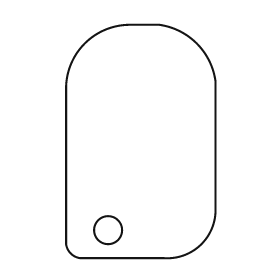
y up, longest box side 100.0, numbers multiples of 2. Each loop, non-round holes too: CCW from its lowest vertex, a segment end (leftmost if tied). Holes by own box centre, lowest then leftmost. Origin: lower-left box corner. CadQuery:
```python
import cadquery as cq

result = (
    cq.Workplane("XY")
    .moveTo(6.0, 0.0)
    .lineTo(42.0, 0.0)
    .threePointArc((58.0, 6.0), (64.0, 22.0))
    .lineTo(64.0, 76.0)
    .threePointArc((56.0, 92.0), (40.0, 100.0))
    .lineTo(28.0, 100.0)
    .threePointArc((8.0, 92.0), (0.0, 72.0))
    .lineTo(0.0, 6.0)
    .threePointArc((2.0, 2.0), (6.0, 0.0))
    .close()
    .moveTo(18.0, 12.0)
    .circle(6.0)
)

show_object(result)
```